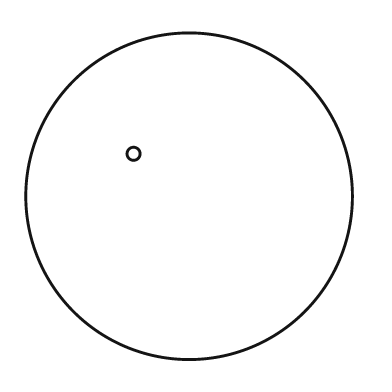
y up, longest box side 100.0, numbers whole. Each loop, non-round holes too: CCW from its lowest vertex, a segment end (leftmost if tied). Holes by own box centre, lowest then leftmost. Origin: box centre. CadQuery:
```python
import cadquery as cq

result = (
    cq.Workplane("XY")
    .moveTo(0.0, 0.0)
    .circle(50.0)
    .moveTo(-17.0, 13.0)
    .circle(2.0)
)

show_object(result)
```